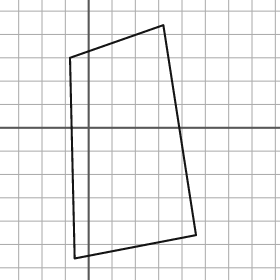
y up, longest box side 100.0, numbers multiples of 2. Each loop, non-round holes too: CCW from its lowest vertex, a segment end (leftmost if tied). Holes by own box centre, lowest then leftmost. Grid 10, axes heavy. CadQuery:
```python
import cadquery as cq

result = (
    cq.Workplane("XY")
    .moveTo(-6.0, -56.0)
    .lineTo(46.0, -46.0)
    .lineTo(32.0, 44.0)
    .lineTo(-8.0, 30.0)
    .close()
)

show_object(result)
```